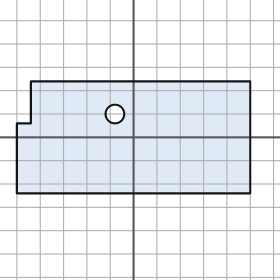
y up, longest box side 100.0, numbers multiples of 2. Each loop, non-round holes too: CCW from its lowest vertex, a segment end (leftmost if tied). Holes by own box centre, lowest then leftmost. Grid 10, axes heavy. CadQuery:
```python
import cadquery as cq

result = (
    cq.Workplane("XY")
    .moveTo(-50.0, -24.0)
    .lineTo(50.0, -24.0)
    .lineTo(50.0, 24.0)
    .lineTo(-44.0, 24.0)
    .lineTo(-44.0, 6.0)
    .lineTo(-50.0, 6.0)
    .close()
    .moveTo(-8.0, 10.0)
    .circle(4.0)
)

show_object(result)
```